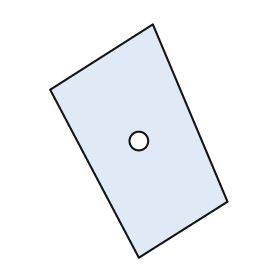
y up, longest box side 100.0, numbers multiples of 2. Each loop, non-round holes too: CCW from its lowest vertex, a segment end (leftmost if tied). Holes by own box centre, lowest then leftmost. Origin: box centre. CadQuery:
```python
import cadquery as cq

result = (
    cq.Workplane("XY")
    .moveTo(0.0, -50.0)
    .lineTo(38.0, -26.0)
    .lineTo(6.0, 50.0)
    .lineTo(-38.0, 22.0)
    .close()
    .moveTo(0.0, 0.0)
    .circle(4.0)
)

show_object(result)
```